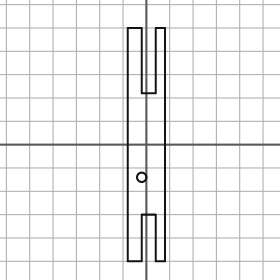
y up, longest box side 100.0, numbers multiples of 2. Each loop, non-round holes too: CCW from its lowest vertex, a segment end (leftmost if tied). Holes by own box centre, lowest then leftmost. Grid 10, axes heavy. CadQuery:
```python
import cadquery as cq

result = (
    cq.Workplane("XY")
    .moveTo(-8.0, -50.0)
    .lineTo(-2.0, -50.0)
    .lineTo(-2.0, -30.0)
    .lineTo(4.0, -30.0)
    .lineTo(4.0, -50.0)
    .lineTo(8.0, -50.0)
    .lineTo(8.0, 50.0)
    .lineTo(4.0, 50.0)
    .lineTo(4.0, 22.0)
    .lineTo(-2.0, 22.0)
    .lineTo(-2.0, 50.0)
    .lineTo(-8.0, 50.0)
    .close()
    .moveTo(-2.0, -14.0)
    .circle(2.0)
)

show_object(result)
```